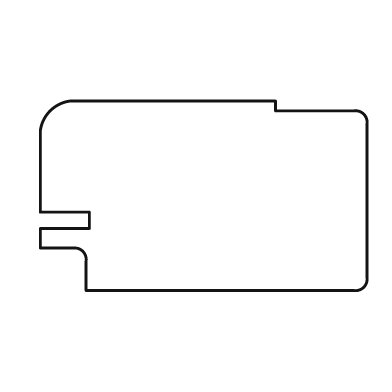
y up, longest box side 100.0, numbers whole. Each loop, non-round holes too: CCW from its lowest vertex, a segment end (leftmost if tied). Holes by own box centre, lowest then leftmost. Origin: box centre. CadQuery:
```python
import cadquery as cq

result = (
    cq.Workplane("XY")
    .moveTo(-36.0, -29.0)
    .lineTo(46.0, -29.0)
    .threePointArc((49.0, -28.0), (50.0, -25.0))
    .lineTo(50.0, 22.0)
    .threePointArc((49.0, 25.0), (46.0, 26.0))
    .lineTo(22.0, 26.0)
    .lineTo(22.0, 29.0)
    .lineTo(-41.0, 29.0)
    .threePointArc((-47.0, 26.0), (-50.0, 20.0))
    .lineTo(-50.0, -5.0)
    .lineTo(-35.0, -5.0)
    .lineTo(-35.0, -10.0)
    .lineTo(-50.0, -10.0)
    .lineTo(-50.0, -16.0)
    .lineTo(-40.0, -16.0)
    .threePointArc((-37.0, -17.0), (-36.0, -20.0))
    .close()
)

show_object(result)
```